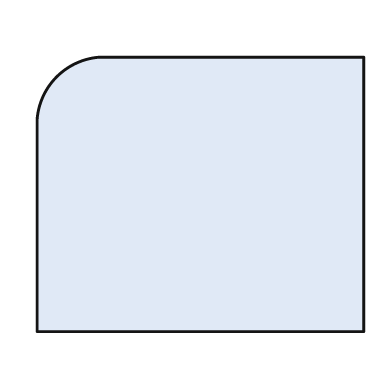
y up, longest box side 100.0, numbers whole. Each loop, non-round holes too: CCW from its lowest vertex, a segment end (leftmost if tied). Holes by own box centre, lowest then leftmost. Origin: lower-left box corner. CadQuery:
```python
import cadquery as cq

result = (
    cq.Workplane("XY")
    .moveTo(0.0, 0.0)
    .lineTo(100.0, 0.0)
    .lineTo(100.0, 84.0)
    .lineTo(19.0, 84.0)
    .threePointArc((6.0, 78.0), (0.0, 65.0))
    .close()
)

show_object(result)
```